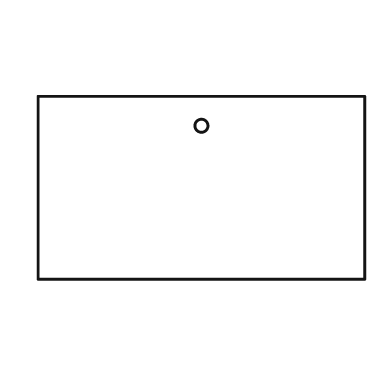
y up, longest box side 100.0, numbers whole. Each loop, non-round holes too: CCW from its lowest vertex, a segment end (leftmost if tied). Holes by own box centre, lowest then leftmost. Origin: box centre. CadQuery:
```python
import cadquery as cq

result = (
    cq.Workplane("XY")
    .moveTo(-50.0, -28.0)
    .lineTo(50.0, -28.0)
    .lineTo(50.0, 28.0)
    .lineTo(-50.0, 28.0)
    .close()
    .moveTo(0.0, 19.0)
    .circle(2.0)
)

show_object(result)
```